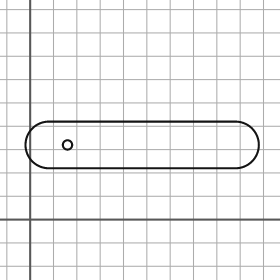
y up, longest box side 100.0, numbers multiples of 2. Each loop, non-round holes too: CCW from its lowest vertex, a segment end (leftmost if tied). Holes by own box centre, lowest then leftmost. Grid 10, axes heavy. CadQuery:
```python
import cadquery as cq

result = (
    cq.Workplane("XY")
    .moveTo(8.0, 22.0)
    .lineTo(88.0, 22.0)
    .threePointArc((98.0, 32.0), (88.0, 42.0))
    .lineTo(8.0, 42.0)
    .threePointArc((-2.0, 32.0), (8.0, 22.0))
    .close()
    .moveTo(16.0, 32.0)
    .circle(2.0)
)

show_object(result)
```